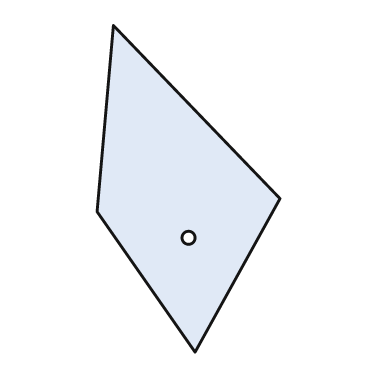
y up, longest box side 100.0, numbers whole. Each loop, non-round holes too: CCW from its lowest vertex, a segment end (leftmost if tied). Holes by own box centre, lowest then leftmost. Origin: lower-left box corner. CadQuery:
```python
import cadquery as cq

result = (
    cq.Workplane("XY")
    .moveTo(30.0, 0.0)
    .lineTo(56.0, 47.0)
    .lineTo(5.0, 100.0)
    .lineTo(0.0, 43.0)
    .close()
    .moveTo(28.0, 35.0)
    .circle(2.0)
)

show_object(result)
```